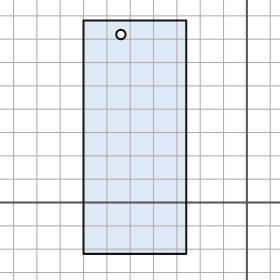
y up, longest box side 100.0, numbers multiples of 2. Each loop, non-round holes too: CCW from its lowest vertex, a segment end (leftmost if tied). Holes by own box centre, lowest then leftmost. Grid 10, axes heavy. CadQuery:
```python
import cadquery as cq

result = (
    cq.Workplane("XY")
    .moveTo(-70.0, -22.0)
    .lineTo(-26.0, -22.0)
    .lineTo(-26.0, 78.0)
    .lineTo(-70.0, 78.0)
    .close()
    .moveTo(-54.0, 72.0)
    .circle(2.0)
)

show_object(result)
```